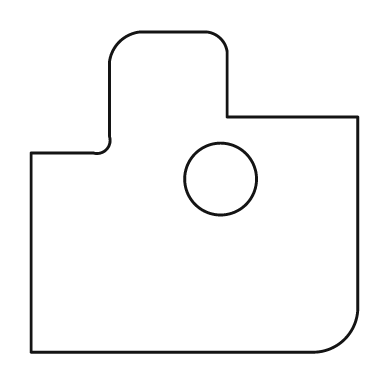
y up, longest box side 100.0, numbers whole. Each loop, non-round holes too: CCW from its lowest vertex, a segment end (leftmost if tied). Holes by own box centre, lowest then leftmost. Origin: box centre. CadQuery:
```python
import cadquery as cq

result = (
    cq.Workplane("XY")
    .moveTo(-50.0, -49.0)
    .lineTo(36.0, -49.0)
    .threePointArc((46.0, -45.0), (50.0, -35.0))
    .lineTo(50.0, 23.0)
    .lineTo(10.0, 23.0)
    .lineTo(10.0, 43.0)
    .threePointArc((8.0, 47.0), (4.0, 49.0))
    .lineTo(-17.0, 49.0)
    .threePointArc((-23.0, 46.0), (-26.0, 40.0))
    .lineTo(-26.0, 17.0)
    .threePointArc((-27.0, 13.0), (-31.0, 12.0))
    .lineTo(-50.0, 12.0)
    .close()
    .moveTo(8.0, 4.0)
    .circle(11.0)
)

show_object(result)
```